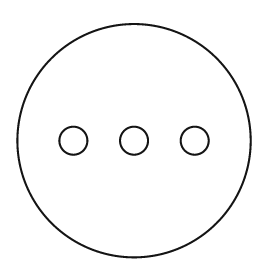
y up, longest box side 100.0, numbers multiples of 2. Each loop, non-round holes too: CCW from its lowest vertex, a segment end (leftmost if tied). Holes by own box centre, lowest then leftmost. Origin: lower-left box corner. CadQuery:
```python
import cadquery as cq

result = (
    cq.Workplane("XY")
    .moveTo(50.0, 50.0)
    .circle(50.0)
    .moveTo(24.0, 50.0)
    .circle(6.0)
    .moveTo(50.0, 50.0)
    .circle(6.0)
    .moveTo(76.0, 50.0)
    .circle(6.0)
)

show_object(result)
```